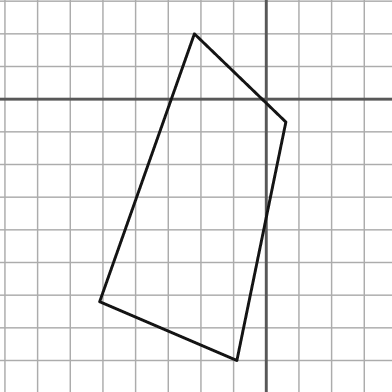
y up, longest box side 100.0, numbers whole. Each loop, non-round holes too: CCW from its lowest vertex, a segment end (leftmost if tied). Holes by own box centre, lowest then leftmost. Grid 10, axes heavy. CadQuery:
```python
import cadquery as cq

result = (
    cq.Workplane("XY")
    .moveTo(-9.0, -80.0)
    .lineTo(6.0, -7.0)
    .lineTo(-22.0, 20.0)
    .lineTo(-51.0, -62.0)
    .close()
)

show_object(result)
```